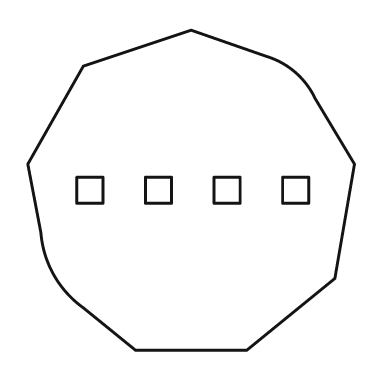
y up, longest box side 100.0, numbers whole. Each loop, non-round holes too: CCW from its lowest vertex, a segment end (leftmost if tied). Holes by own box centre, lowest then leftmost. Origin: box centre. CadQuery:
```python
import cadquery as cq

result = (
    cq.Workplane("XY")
    .moveTo(-17.0, -49.0)
    .lineTo(17.0, -49.0)
    .lineTo(44.0, -27.0)
    .lineTo(50.0, 8.0)
    .lineTo(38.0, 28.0)
    .threePointArc((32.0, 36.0), (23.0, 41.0))
    .lineTo(0.0, 49.0)
    .lineTo(-33.0, 38.0)
    .lineTo(-50.0, 8.0)
    .lineTo(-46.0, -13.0)
    .threePointArc((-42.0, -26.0), (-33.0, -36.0))
    .close()
    .moveTo(-35.0, -4.0)
    .lineTo(-27.0, -4.0)
    .lineTo(-27.0, 4.0)
    .lineTo(-35.0, 4.0)
    .close()
    .moveTo(-14.0, -4.0)
    .lineTo(-6.0, -4.0)
    .lineTo(-6.0, 4.0)
    .lineTo(-14.0, 4.0)
    .close()
    .moveTo(7.0, -4.0)
    .lineTo(15.0, -4.0)
    .lineTo(15.0, 4.0)
    .lineTo(7.0, 4.0)
    .close()
    .moveTo(28.0, -4.0)
    .lineTo(36.0, -4.0)
    .lineTo(36.0, 4.0)
    .lineTo(28.0, 4.0)
    .close()
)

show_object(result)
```